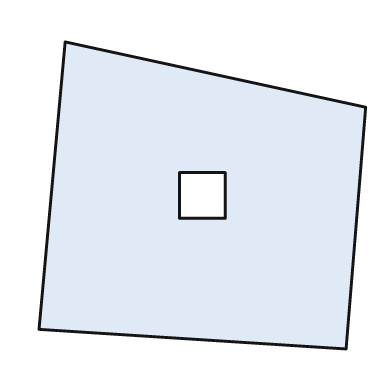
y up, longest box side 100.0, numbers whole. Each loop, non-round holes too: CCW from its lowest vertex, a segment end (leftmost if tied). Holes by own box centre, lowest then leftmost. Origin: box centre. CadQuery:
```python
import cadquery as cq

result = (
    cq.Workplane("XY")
    .moveTo(44.0, -47.0)
    .lineTo(50.0, 27.0)
    .lineTo(-42.0, 47.0)
    .lineTo(-50.0, -41.0)
    .close()
    .moveTo(-7.0, -7.0)
    .lineTo(7.0, -7.0)
    .lineTo(7.0, 7.0)
    .lineTo(-7.0, 7.0)
    .close()
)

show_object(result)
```